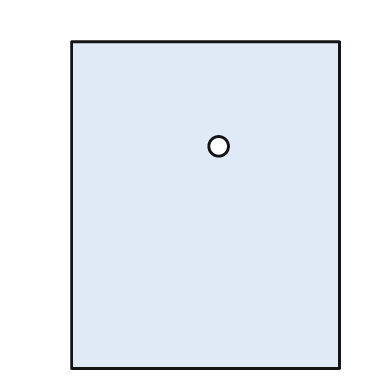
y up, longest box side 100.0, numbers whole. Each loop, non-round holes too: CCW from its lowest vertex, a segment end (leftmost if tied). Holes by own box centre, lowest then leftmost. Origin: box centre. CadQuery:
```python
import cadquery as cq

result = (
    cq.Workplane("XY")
    .moveTo(-41.0, -50.0)
    .lineTo(41.0, -50.0)
    .lineTo(41.0, 50.0)
    .lineTo(-41.0, 50.0)
    .close()
    .moveTo(4.0, 18.0)
    .circle(3.0)
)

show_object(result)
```